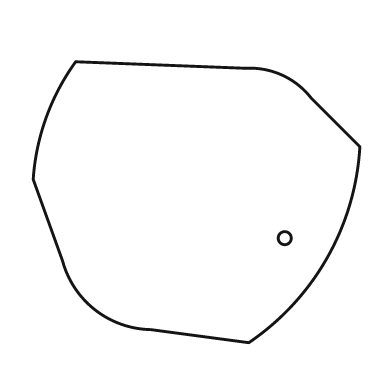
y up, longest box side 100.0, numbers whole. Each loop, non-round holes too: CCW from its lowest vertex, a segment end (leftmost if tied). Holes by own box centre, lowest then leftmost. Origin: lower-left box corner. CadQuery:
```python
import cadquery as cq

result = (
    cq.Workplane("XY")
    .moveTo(66.0, 0.0)
    .threePointArc((90.0, 26.0), (100.0, 60.0))
    .lineTo(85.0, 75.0)
    .threePointArc((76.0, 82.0), (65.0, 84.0))
    .lineTo(13.0, 86.0)
    .threePointArc((4.0, 69.0), (0.0, 50.0))
    .lineTo(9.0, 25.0)
    .threePointArc((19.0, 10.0), (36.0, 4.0))
    .close()
    .moveTo(77.0, 32.0)
    .circle(2.0)
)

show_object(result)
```